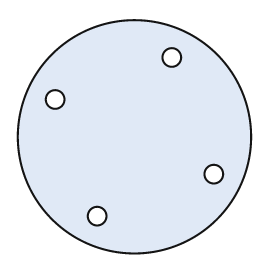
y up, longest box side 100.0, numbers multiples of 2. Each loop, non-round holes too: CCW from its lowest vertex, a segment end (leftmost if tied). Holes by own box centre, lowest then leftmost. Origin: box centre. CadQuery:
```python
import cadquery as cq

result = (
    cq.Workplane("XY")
    .moveTo(0.0, 0.0)
    .circle(50.0)
    .moveTo(-16.0, -34.0)
    .circle(4.0)
    .moveTo(34.0, -16.0)
    .circle(4.0)
    .moveTo(-34.0, 16.0)
    .circle(4.0)
    .moveTo(16.0, 34.0)
    .circle(4.0)
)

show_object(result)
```